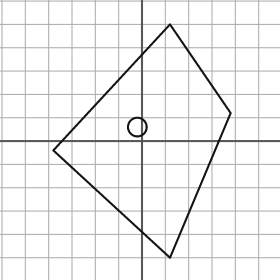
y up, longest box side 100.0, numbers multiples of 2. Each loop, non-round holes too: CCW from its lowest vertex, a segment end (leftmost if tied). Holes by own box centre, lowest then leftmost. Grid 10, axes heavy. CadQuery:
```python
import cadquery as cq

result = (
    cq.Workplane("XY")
    .moveTo(12.0, -50.0)
    .lineTo(38.0, 12.0)
    .lineTo(12.0, 50.0)
    .lineTo(-38.0, -4.0)
    .close()
    .moveTo(-2.0, 6.0)
    .circle(4.0)
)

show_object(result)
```